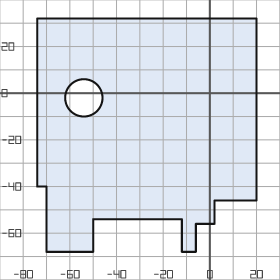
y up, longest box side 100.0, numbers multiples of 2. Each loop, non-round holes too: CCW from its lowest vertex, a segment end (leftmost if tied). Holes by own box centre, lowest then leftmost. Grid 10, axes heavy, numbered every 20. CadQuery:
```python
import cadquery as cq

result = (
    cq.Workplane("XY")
    .moveTo(-70.0, -68.0)
    .lineTo(-50.0, -68.0)
    .lineTo(-50.0, -54.0)
    .lineTo(-12.0, -54.0)
    .lineTo(-12.0, -68.0)
    .lineTo(-6.0, -68.0)
    .lineTo(-6.0, -56.0)
    .lineTo(2.0, -56.0)
    .lineTo(2.0, -46.0)
    .lineTo(20.0, -46.0)
    .lineTo(20.0, 32.0)
    .lineTo(-74.0, 32.0)
    .lineTo(-74.0, -40.0)
    .lineTo(-70.0, -40.0)
    .close()
    .moveTo(-54.0, -2.0)
    .circle(8.0)
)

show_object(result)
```